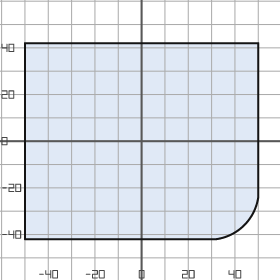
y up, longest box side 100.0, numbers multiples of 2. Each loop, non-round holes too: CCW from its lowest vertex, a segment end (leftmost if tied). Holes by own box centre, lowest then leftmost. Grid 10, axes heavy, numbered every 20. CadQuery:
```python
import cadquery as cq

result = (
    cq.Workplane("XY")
    .moveTo(-50.0, -42.0)
    .lineTo(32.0, -42.0)
    .threePointArc((44.0, -36.0), (50.0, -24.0))
    .lineTo(50.0, 42.0)
    .lineTo(-50.0, 42.0)
    .close()
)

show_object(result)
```